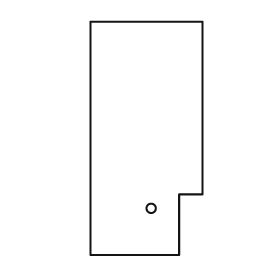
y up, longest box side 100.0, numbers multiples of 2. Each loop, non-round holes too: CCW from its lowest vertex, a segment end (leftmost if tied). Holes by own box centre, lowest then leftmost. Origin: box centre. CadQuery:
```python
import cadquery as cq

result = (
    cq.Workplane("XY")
    .moveTo(-24.0, -50.0)
    .lineTo(14.0, -50.0)
    .lineTo(14.0, -24.0)
    .lineTo(24.0, -24.0)
    .lineTo(24.0, 50.0)
    .lineTo(-24.0, 50.0)
    .close()
    .moveTo(2.0, -30.0)
    .circle(2.0)
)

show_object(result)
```